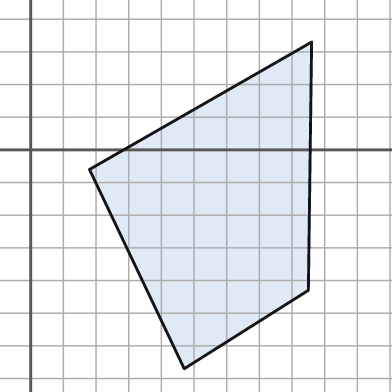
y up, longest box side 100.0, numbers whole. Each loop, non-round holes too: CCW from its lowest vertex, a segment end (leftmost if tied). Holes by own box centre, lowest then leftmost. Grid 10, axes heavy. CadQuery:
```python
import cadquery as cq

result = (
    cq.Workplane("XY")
    .moveTo(47.0, -67.0)
    .lineTo(85.0, -43.0)
    .lineTo(86.0, 33.0)
    .lineTo(18.0, -6.0)
    .close()
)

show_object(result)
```